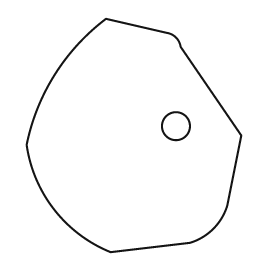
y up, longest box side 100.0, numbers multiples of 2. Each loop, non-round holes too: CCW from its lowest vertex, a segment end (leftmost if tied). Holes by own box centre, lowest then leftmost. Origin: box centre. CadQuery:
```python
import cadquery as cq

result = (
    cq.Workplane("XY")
    .moveTo(-10.0, -50.0)
    .lineTo(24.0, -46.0)
    .threePointArc((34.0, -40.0), (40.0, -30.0))
    .lineTo(46.0, 0.0)
    .lineTo(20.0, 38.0)
    .threePointArc((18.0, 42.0), (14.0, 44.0))
    .lineTo(-12.0, 50.0)
    .threePointArc((-34.0, 26.0), (-46.0, -4.0))
    .threePointArc((-34.0, -32.0), (-10.0, -50.0))
    .close()
    .moveTo(18.0, 4.0)
    .circle(6.0)
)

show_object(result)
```